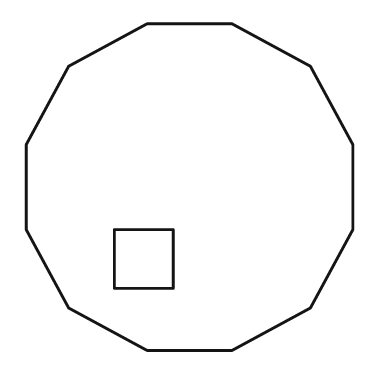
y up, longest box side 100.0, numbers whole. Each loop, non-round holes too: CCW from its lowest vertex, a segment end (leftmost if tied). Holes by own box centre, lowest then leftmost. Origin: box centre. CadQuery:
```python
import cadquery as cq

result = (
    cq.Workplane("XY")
    .moveTo(-13.0, -50.0)
    .lineTo(13.0, -50.0)
    .lineTo(37.0, -37.0)
    .lineTo(50.0, -13.0)
    .lineTo(50.0, 13.0)
    .lineTo(37.0, 37.0)
    .lineTo(13.0, 50.0)
    .lineTo(-13.0, 50.0)
    .lineTo(-37.0, 37.0)
    .lineTo(-50.0, 13.0)
    .lineTo(-50.0, -13.0)
    .lineTo(-37.0, -37.0)
    .close()
    .moveTo(-23.0, -31.0)
    .lineTo(-5.0, -31.0)
    .lineTo(-5.0, -13.0)
    .lineTo(-23.0, -13.0)
    .close()
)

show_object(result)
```